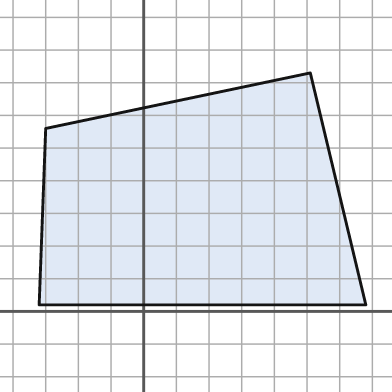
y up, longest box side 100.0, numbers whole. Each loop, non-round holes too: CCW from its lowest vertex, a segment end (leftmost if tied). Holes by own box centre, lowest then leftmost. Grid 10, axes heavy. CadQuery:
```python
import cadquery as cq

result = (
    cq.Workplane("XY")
    .moveTo(-32.0, 2.0)
    .lineTo(68.0, 2.0)
    .lineTo(51.0, 73.0)
    .lineTo(-30.0, 56.0)
    .close()
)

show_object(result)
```